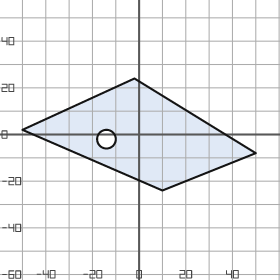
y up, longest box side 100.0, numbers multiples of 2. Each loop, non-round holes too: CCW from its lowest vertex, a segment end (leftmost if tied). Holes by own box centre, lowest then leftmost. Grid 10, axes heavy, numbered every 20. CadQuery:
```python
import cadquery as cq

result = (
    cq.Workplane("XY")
    .moveTo(10.0, -24.0)
    .lineTo(50.0, -8.0)
    .lineTo(-2.0, 24.0)
    .lineTo(-50.0, 2.0)
    .close()
    .moveTo(-14.0, -2.0)
    .circle(4.0)
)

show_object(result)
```